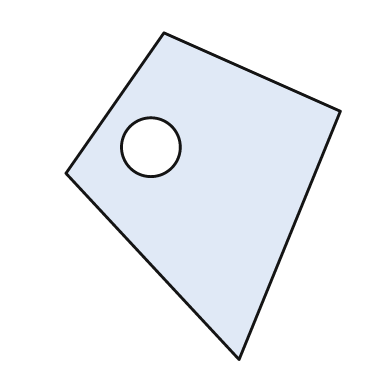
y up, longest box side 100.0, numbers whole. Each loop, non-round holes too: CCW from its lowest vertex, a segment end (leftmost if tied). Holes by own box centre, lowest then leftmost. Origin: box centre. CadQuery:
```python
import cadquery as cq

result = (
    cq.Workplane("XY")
    .moveTo(11.0, -50.0)
    .lineTo(42.0, 26.0)
    .lineTo(-12.0, 50.0)
    .lineTo(-42.0, 7.0)
    .close()
    .moveTo(-16.0, 15.0)
    .circle(9.0)
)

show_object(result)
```